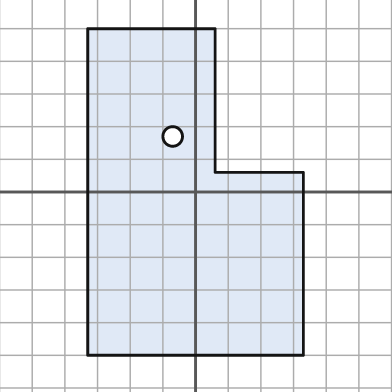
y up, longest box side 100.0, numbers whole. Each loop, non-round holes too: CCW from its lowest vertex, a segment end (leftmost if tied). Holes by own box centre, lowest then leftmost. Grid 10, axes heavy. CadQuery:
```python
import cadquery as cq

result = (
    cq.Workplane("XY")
    .moveTo(-33.0, -50.0)
    .lineTo(33.0, -50.0)
    .lineTo(33.0, 6.0)
    .lineTo(6.0, 6.0)
    .lineTo(6.0, 50.0)
    .lineTo(-33.0, 50.0)
    .close()
    .moveTo(-7.0, 17.0)
    .circle(3.0)
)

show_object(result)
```